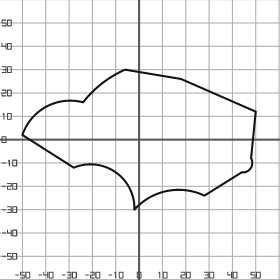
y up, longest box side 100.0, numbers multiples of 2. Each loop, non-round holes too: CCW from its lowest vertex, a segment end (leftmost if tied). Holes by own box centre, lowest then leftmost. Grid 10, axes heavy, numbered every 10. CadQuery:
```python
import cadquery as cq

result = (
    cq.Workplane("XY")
    .moveTo(-2.0, -30.0)
    .threePointArc((12.0, -22.0), (28.0, -24.0))
    .lineTo(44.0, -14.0)
    .threePointArc((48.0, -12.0), (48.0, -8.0))
    .lineTo(50.0, 12.0)
    .lineTo(18.0, 26.0)
    .lineTo(-6.0, 30.0)
    .threePointArc((-16.0, 24.0), (-24.0, 16.0))
    .threePointArc((-40.0, 14.0), (-50.0, 2.0))
    .lineTo(-28.0, -12.0)
    .threePointArc((-10.0, -14.0), (-2.0, -30.0))
    .close()
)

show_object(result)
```